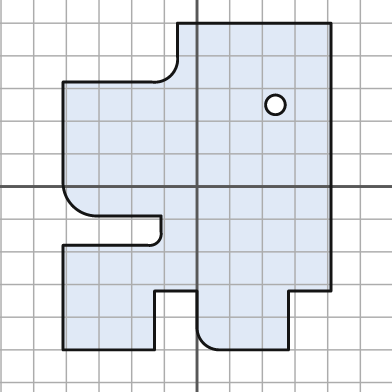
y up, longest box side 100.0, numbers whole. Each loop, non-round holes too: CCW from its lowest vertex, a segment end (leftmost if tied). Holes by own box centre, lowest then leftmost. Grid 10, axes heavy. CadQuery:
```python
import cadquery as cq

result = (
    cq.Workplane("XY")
    .moveTo(-41.0, -50.0)
    .lineTo(-13.0, -50.0)
    .lineTo(-13.0, -32.0)
    .lineTo(0.0, -32.0)
    .lineTo(0.0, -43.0)
    .threePointArc((2.0, -48.0), (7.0, -50.0))
    .lineTo(28.0, -50.0)
    .lineTo(28.0, -32.0)
    .lineTo(41.0, -32.0)
    .lineTo(41.0, 50.0)
    .lineTo(-6.0, 50.0)
    .lineTo(-6.0, 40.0)
    .threePointArc((-8.0, 34.0), (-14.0, 32.0))
    .lineTo(-41.0, 32.0)
    .lineTo(-41.0, 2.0)
    .threePointArc((-38.0, -6.0), (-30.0, -9.0))
    .lineTo(-11.0, -9.0)
    .lineTo(-11.0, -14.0)
    .threePointArc((-12.0, -17.0), (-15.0, -18.0))
    .lineTo(-41.0, -18.0)
    .close()
    .moveTo(24.0, 25.0)
    .circle(3.0)
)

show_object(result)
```